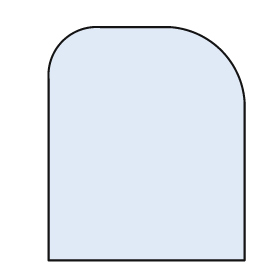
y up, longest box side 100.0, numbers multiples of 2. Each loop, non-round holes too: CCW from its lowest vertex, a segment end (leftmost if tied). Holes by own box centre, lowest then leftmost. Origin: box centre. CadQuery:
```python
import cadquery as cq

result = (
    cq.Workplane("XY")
    .moveTo(-42.0, -50.0)
    .lineTo(42.0, -50.0)
    .lineTo(42.0, 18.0)
    .threePointArc((32.0, 40.0), (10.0, 50.0))
    .lineTo(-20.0, 50.0)
    .threePointArc((-36.0, 44.0), (-42.0, 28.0))
    .close()
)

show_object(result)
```